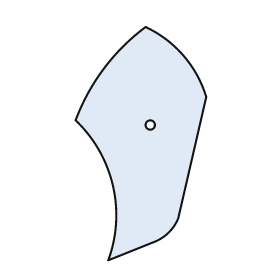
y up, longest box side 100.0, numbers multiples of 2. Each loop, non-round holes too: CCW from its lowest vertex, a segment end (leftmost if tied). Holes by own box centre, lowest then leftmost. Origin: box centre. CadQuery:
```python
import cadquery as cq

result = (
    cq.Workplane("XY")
    .moveTo(-14.0, -50.0)
    .lineTo(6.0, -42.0)
    .threePointArc((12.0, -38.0), (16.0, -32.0))
    .lineTo(28.0, 20.0)
    .threePointArc((18.0, 38.0), (2.0, 50.0))
    .threePointArc((-16.0, 32.0), (-28.0, 10.0))
    .threePointArc((-12.0, -18.0), (-14.0, -50.0))
    .close()
    .moveTo(4.0, 8.0)
    .circle(2.0)
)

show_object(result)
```